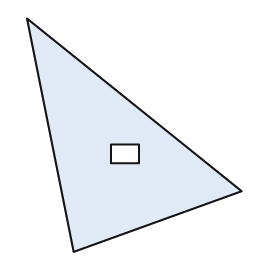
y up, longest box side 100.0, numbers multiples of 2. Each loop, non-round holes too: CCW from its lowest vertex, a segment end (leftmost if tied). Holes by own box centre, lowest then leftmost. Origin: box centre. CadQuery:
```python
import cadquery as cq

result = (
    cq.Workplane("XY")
    .moveTo(-26.0, -50.0)
    .lineTo(46.0, -24.0)
    .lineTo(-46.0, 50.0)
    .close()
    .moveTo(-10.0, -12.0)
    .lineTo(2.0, -12.0)
    .lineTo(2.0, -4.0)
    .lineTo(-10.0, -4.0)
    .close()
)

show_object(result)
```